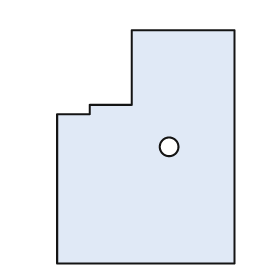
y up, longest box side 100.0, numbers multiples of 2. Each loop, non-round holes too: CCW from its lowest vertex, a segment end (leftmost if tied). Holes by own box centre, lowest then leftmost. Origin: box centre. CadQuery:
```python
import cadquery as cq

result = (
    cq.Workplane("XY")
    .moveTo(-38.0, -50.0)
    .lineTo(38.0, -50.0)
    .lineTo(38.0, 50.0)
    .lineTo(-6.0, 50.0)
    .lineTo(-6.0, 18.0)
    .lineTo(-24.0, 18.0)
    .lineTo(-24.0, 14.0)
    .lineTo(-38.0, 14.0)
    .close()
    .moveTo(10.0, 0.0)
    .circle(4.0)
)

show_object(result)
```